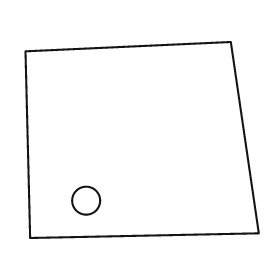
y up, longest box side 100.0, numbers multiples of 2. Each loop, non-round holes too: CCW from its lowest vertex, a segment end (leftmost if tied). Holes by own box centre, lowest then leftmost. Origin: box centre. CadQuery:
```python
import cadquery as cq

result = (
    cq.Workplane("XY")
    .moveTo(-48.0, -42.0)
    .lineTo(50.0, -40.0)
    .lineTo(38.0, 42.0)
    .lineTo(-50.0, 38.0)
    .close()
    .moveTo(-24.0, -26.0)
    .circle(6.0)
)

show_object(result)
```